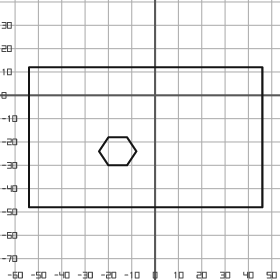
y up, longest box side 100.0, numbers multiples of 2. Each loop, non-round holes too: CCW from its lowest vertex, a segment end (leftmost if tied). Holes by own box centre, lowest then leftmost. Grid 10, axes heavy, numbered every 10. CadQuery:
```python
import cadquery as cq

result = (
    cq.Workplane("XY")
    .moveTo(-54.0, -48.0)
    .lineTo(46.0, -48.0)
    .lineTo(46.0, 12.0)
    .lineTo(-54.0, 12.0)
    .close()
    .moveTo(-20.0, -30.0)
    .lineTo(-12.0, -30.0)
    .lineTo(-8.0, -24.0)
    .lineTo(-12.0, -18.0)
    .lineTo(-20.0, -18.0)
    .lineTo(-24.0, -24.0)
    .close()
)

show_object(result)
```